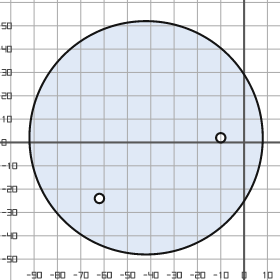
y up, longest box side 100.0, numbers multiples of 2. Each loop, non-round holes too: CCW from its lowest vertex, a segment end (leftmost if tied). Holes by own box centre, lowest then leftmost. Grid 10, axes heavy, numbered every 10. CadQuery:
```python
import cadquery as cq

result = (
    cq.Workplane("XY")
    .moveTo(-42.0, 2.0)
    .circle(50.0)
    .moveTo(-62.0, -24.0)
    .circle(2.0)
    .moveTo(-10.0, 2.0)
    .circle(2.0)
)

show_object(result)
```